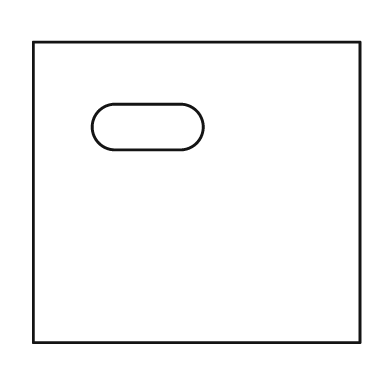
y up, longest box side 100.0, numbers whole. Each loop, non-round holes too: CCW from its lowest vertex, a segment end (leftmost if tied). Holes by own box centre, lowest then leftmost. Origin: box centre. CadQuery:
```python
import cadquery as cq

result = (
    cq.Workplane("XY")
    .moveTo(-50.0, -46.0)
    .lineTo(50.0, -46.0)
    .lineTo(50.0, 46.0)
    .lineTo(-50.0, 46.0)
    .close()
    .moveTo(-25.0, 13.0)
    .lineTo(-5.0, 13.0)
    .threePointArc((2.0, 20.0), (-5.0, 27.0))
    .lineTo(-25.0, 27.0)
    .threePointArc((-32.0, 20.0), (-25.0, 13.0))
    .close()
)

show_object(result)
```